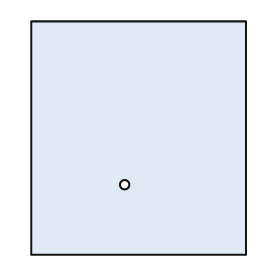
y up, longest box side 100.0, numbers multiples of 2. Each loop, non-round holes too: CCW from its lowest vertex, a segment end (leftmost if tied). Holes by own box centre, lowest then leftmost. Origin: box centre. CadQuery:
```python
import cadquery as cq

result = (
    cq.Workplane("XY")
    .moveTo(-46.0, -50.0)
    .lineTo(46.0, -50.0)
    .lineTo(46.0, 50.0)
    .lineTo(-46.0, 50.0)
    .close()
    .moveTo(-6.0, -20.0)
    .circle(2.0)
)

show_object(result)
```